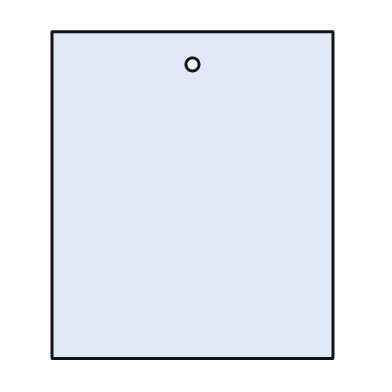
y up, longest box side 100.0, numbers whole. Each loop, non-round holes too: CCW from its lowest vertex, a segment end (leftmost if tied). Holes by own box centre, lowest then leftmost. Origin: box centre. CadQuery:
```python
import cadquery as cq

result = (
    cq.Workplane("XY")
    .moveTo(-43.0, -50.0)
    .lineTo(43.0, -50.0)
    .lineTo(43.0, 50.0)
    .lineTo(-43.0, 50.0)
    .close()
    .moveTo(0.0, 40.0)
    .circle(2.0)
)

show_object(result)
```